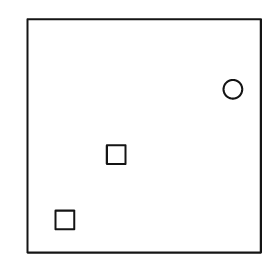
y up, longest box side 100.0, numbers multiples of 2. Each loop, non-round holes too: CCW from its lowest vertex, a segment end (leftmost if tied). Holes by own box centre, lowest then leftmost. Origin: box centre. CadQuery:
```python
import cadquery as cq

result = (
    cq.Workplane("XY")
    .moveTo(-50.0, -50.0)
    .lineTo(50.0, -50.0)
    .lineTo(50.0, 50.0)
    .lineTo(-50.0, 50.0)
    .close()
    .moveTo(-38.0, -40.0)
    .lineTo(-30.0, -40.0)
    .lineTo(-30.0, -32.0)
    .lineTo(-38.0, -32.0)
    .close()
    .moveTo(-16.0, -12.0)
    .lineTo(-8.0, -12.0)
    .lineTo(-8.0, -4.0)
    .lineTo(-16.0, -4.0)
    .close()
    .moveTo(38.0, 20.0)
    .circle(4.0)
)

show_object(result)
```